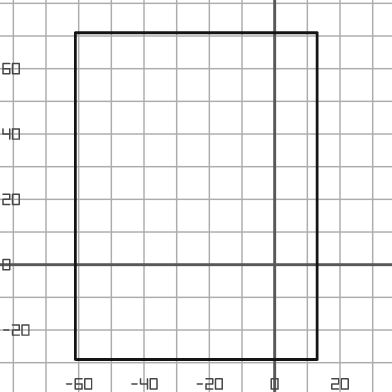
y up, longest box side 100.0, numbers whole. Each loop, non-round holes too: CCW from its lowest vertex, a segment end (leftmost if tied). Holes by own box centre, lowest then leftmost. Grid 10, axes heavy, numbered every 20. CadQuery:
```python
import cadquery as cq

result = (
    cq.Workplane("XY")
    .moveTo(-61.0, -29.0)
    .lineTo(13.0, -29.0)
    .lineTo(13.0, 71.0)
    .lineTo(-61.0, 71.0)
    .close()
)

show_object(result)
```